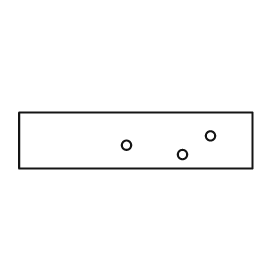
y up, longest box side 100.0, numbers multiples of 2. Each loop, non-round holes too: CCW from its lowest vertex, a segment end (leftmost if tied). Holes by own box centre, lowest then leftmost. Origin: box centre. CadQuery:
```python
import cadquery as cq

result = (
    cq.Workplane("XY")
    .moveTo(-50.0, -12.0)
    .lineTo(50.0, -12.0)
    .lineTo(50.0, 12.0)
    .lineTo(-50.0, 12.0)
    .close()
    .moveTo(20.0, -6.0)
    .circle(2.0)
    .moveTo(-4.0, -2.0)
    .circle(2.0)
    .moveTo(32.0, 2.0)
    .circle(2.0)
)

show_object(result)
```